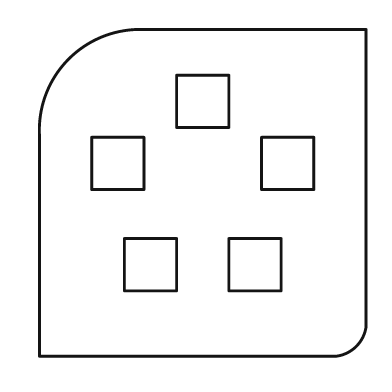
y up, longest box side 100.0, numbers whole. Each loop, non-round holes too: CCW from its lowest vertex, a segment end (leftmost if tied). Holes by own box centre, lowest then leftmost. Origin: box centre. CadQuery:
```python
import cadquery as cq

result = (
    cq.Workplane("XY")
    .moveTo(-50.0, -50.0)
    .lineTo(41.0, -50.0)
    .threePointArc((47.0, -47.0), (50.0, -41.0))
    .lineTo(50.0, 50.0)
    .lineTo(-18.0, 50.0)
    .threePointArc((-41.0, 41.0), (-50.0, 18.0))
    .close()
    .moveTo(-24.0, -30.0)
    .lineTo(-8.0, -30.0)
    .lineTo(-8.0, -14.0)
    .lineTo(-24.0, -14.0)
    .close()
    .moveTo(8.0, -30.0)
    .lineTo(24.0, -30.0)
    .lineTo(24.0, -14.0)
    .lineTo(8.0, -14.0)
    .close()
    .moveTo(-34.0, 1.0)
    .lineTo(-18.0, 1.0)
    .lineTo(-18.0, 17.0)
    .lineTo(-34.0, 17.0)
    .close()
    .moveTo(18.0, 1.0)
    .lineTo(34.0, 1.0)
    .lineTo(34.0, 17.0)
    .lineTo(18.0, 17.0)
    .close()
    .moveTo(-8.0, 20.0)
    .lineTo(8.0, 20.0)
    .lineTo(8.0, 36.0)
    .lineTo(-8.0, 36.0)
    .close()
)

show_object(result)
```